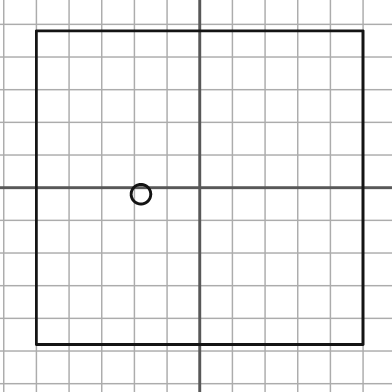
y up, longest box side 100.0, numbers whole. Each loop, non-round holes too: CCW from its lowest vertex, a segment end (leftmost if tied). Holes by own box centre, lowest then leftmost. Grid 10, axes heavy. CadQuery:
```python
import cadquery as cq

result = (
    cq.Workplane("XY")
    .moveTo(-50.0, -48.0)
    .lineTo(50.0, -48.0)
    .lineTo(50.0, 48.0)
    .lineTo(-50.0, 48.0)
    .close()
    .moveTo(-18.0, -2.0)
    .circle(3.0)
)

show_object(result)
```